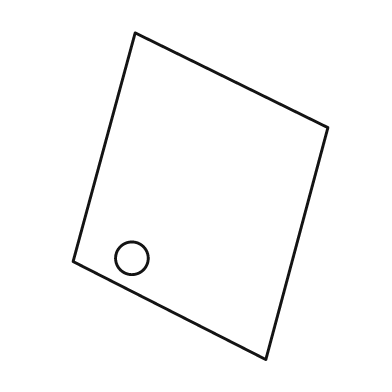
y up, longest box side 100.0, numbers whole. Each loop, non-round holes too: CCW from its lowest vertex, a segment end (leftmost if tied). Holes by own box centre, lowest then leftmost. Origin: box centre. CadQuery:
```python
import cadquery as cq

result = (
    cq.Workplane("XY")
    .moveTo(20.0, -50.0)
    .lineTo(39.0, 21.0)
    .lineTo(-20.0, 50.0)
    .lineTo(-39.0, -20.0)
    .close()
    .moveTo(-21.0, -19.0)
    .circle(5.0)
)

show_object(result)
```